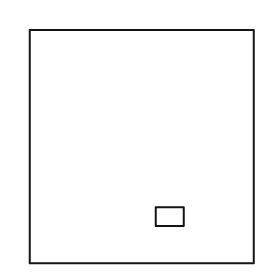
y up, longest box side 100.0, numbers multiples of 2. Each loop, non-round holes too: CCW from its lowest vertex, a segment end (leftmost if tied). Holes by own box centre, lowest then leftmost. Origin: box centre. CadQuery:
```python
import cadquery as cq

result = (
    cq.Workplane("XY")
    .moveTo(-48.0, -50.0)
    .lineTo(48.0, -50.0)
    .lineTo(48.0, 50.0)
    .lineTo(-48.0, 50.0)
    .close()
    .moveTo(6.0, -34.0)
    .lineTo(18.0, -34.0)
    .lineTo(18.0, -26.0)
    .lineTo(6.0, -26.0)
    .close()
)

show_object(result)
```